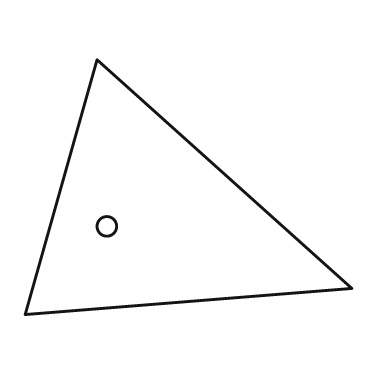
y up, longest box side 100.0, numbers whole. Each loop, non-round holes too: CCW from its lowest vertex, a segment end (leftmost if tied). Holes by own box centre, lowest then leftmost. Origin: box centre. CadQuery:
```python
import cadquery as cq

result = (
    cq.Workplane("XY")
    .moveTo(-50.0, -39.0)
    .lineTo(50.0, -31.0)
    .lineTo(-28.0, 39.0)
    .close()
    .moveTo(-25.0, -12.0)
    .circle(3.0)
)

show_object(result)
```